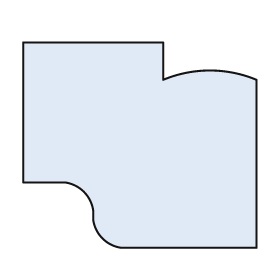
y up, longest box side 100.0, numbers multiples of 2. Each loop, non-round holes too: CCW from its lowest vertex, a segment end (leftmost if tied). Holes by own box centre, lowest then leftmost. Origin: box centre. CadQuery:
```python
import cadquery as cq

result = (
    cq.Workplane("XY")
    .moveTo(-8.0, -44.0)
    .lineTo(50.0, -44.0)
    .lineTo(50.0, 28.0)
    .threePointArc((30.0, 32.0), (10.0, 28.0))
    .lineTo(10.0, 44.0)
    .lineTo(-50.0, 44.0)
    .lineTo(-50.0, -16.0)
    .lineTo(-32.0, -16.0)
    .threePointArc((-24.0, -20.0), (-20.0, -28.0))
    .lineTo(-20.0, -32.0)
    .threePointArc((-16.0, -40.0), (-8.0, -44.0))
    .close()
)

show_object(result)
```